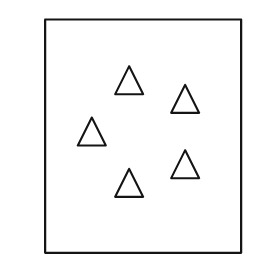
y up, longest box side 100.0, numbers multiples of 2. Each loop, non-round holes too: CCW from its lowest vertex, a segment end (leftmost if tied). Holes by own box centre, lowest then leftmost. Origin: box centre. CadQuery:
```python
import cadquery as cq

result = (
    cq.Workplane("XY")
    .moveTo(-42.0, -50.0)
    .lineTo(42.0, -50.0)
    .lineTo(42.0, 50.0)
    .lineTo(-42.0, 50.0)
    .close()
    .moveTo(-12.0, -26.0)
    .lineTo(0.0, -26.0)
    .lineTo(-6.0, -14.0)
    .close()
    .moveTo(12.0, -18.0)
    .lineTo(24.0, -18.0)
    .lineTo(18.0, -6.0)
    .close()
    .moveTo(-28.0, -4.0)
    .lineTo(-16.0, -4.0)
    .lineTo(-22.0, 8.0)
    .close()
    .moveTo(12.0, 10.0)
    .lineTo(24.0, 10.0)
    .lineTo(18.0, 22.0)
    .close()
    .moveTo(-12.0, 18.0)
    .lineTo(0.0, 18.0)
    .lineTo(-6.0, 30.0)
    .close()
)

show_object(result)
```